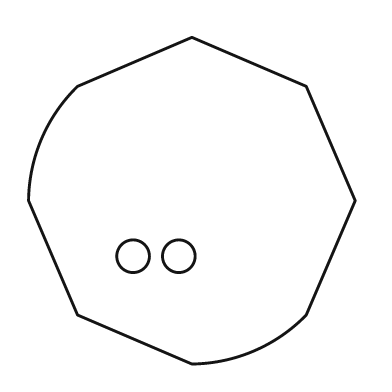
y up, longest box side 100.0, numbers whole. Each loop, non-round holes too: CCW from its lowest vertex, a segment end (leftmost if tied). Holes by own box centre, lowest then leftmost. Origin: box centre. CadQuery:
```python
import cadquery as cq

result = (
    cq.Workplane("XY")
    .moveTo(0.0, -50.0)
    .threePointArc((19.0, -46.0), (35.0, -35.0))
    .lineTo(50.0, 0.0)
    .lineTo(35.0, 35.0)
    .lineTo(0.0, 50.0)
    .lineTo(-35.0, 35.0)
    .threePointArc((-46.0, 19.0), (-50.0, 0.0))
    .lineTo(-35.0, -35.0)
    .close()
    .moveTo(-18.0, -17.0)
    .circle(5.0)
    .moveTo(-4.0, -17.0)
    .circle(5.0)
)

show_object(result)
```